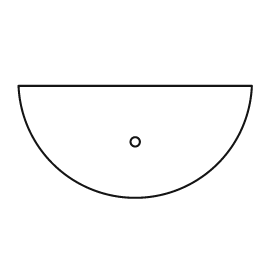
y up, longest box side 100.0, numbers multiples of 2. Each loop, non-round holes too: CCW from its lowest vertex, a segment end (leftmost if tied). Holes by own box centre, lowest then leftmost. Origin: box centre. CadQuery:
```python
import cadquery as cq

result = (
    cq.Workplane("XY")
    .moveTo(-50.0, 24.0)
    .threePointArc((0.0, -24.0), (50.0, 24.0))
    .close()
    .moveTo(0.0, 0.0)
    .circle(2.0)
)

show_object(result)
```